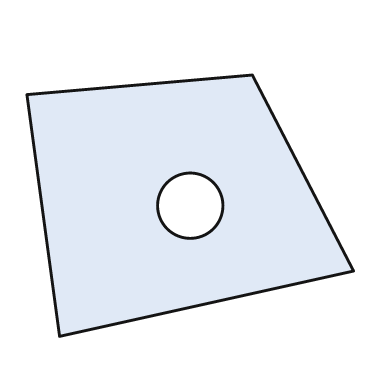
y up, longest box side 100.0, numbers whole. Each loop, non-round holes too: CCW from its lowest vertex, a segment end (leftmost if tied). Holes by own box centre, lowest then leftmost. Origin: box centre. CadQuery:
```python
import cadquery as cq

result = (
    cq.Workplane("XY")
    .moveTo(-40.0, -40.0)
    .lineTo(50.0, -20.0)
    .lineTo(19.0, 40.0)
    .lineTo(-50.0, 34.0)
    .close()
    .moveTo(0.0, 0.0)
    .circle(10.0)
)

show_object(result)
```